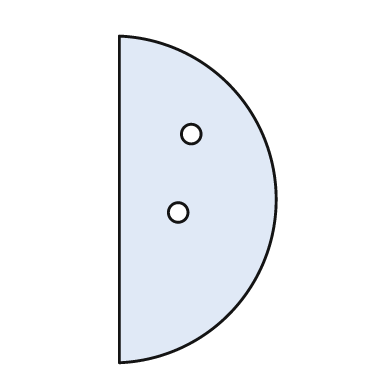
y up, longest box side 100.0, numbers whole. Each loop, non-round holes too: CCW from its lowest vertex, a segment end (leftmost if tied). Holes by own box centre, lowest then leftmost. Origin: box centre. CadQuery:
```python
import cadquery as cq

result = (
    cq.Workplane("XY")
    .moveTo(-24.0, -50.0)
    .threePointArc((24.0, 0.0), (-24.0, 50.0))
    .close()
    .moveTo(-6.0, -4.0)
    .circle(3.0)
    .moveTo(-2.0, 20.0)
    .circle(3.0)
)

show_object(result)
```